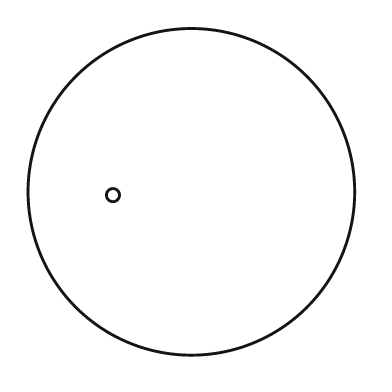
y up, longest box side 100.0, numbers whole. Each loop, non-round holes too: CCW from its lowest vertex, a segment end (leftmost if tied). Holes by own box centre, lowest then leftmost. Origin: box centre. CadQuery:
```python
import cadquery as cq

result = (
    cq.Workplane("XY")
    .moveTo(0.0, 0.0)
    .circle(50.0)
    .moveTo(-24.0, -1.0)
    .circle(2.0)
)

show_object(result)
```